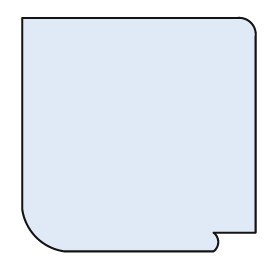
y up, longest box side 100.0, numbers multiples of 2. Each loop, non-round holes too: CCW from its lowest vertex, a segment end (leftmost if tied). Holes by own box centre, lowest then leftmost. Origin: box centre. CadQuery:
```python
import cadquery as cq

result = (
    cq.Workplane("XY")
    .moveTo(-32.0, -50.0)
    .lineTo(32.0, -50.0)
    .threePointArc((34.0, -46.0), (32.0, -42.0))
    .lineTo(50.0, -42.0)
    .lineTo(50.0, 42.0)
    .threePointArc((48.0, 48.0), (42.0, 50.0))
    .lineTo(-50.0, 50.0)
    .lineTo(-50.0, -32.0)
    .threePointArc((-44.0, -44.0), (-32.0, -50.0))
    .close()
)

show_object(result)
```